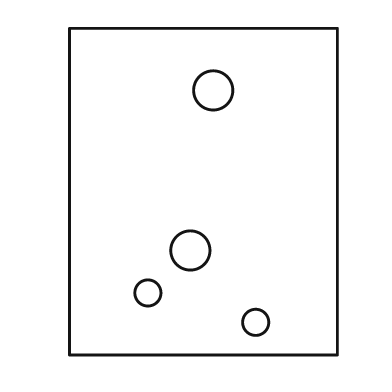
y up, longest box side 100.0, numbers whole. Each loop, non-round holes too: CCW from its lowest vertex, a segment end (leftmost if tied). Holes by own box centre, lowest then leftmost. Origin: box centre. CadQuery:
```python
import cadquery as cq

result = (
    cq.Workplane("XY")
    .moveTo(-41.0, -50.0)
    .lineTo(41.0, -50.0)
    .lineTo(41.0, 50.0)
    .lineTo(-41.0, 50.0)
    .close()
    .moveTo(16.0, -40.0)
    .circle(4.0)
    .moveTo(-17.0, -31.0)
    .circle(4.0)
    .moveTo(-4.0, -18.0)
    .circle(6.0)
    .moveTo(3.0, 31.0)
    .circle(6.0)
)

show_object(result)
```